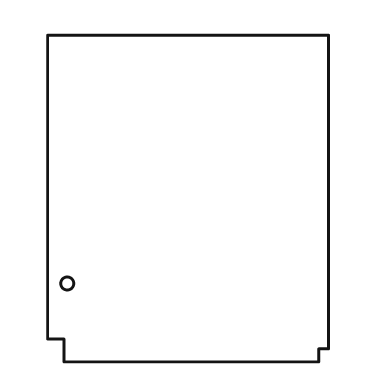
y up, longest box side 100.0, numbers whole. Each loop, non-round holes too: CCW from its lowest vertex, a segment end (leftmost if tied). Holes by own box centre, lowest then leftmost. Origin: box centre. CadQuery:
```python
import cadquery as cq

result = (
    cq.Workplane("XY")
    .moveTo(-38.0, -50.0)
    .lineTo(40.0, -50.0)
    .lineTo(40.0, -46.0)
    .lineTo(43.0, -46.0)
    .lineTo(43.0, 50.0)
    .lineTo(-43.0, 50.0)
    .lineTo(-43.0, -43.0)
    .lineTo(-38.0, -43.0)
    .close()
    .moveTo(-37.0, -26.0)
    .circle(2.0)
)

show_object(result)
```